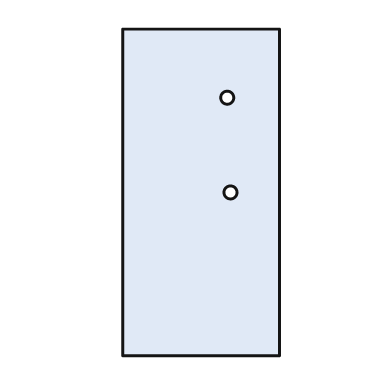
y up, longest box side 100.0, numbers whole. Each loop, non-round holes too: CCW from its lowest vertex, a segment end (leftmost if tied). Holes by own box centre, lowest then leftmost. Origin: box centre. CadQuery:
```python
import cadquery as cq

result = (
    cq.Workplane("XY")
    .moveTo(-24.0, -50.0)
    .lineTo(24.0, -50.0)
    .lineTo(24.0, 50.0)
    .lineTo(-24.0, 50.0)
    .close()
    .moveTo(9.0, 0.0)
    .circle(2.0)
    .moveTo(8.0, 29.0)
    .circle(2.0)
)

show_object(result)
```